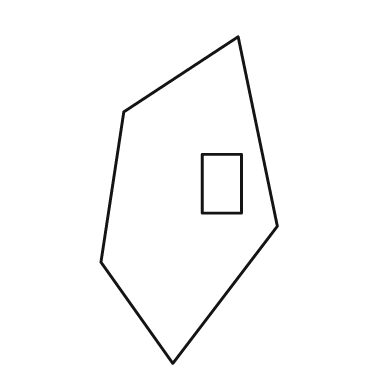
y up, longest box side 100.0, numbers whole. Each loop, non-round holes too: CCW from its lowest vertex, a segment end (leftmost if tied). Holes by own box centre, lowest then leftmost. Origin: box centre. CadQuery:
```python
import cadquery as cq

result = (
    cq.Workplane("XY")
    .moveTo(-5.0, -50.0)
    .lineTo(27.0, -8.0)
    .lineTo(15.0, 50.0)
    .lineTo(-20.0, 27.0)
    .lineTo(-27.0, -19.0)
    .close()
    .moveTo(4.0, -4.0)
    .lineTo(16.0, -4.0)
    .lineTo(16.0, 14.0)
    .lineTo(4.0, 14.0)
    .close()
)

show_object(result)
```